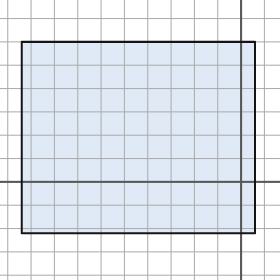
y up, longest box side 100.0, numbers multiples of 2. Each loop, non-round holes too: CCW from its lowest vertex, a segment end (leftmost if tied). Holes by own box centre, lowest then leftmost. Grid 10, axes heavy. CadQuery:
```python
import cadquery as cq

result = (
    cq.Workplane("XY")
    .moveTo(-94.0, -22.0)
    .lineTo(6.0, -22.0)
    .lineTo(6.0, 60.0)
    .lineTo(-94.0, 60.0)
    .close()
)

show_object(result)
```